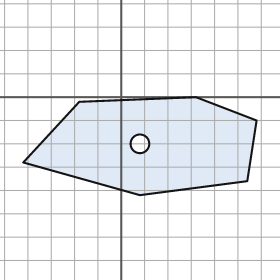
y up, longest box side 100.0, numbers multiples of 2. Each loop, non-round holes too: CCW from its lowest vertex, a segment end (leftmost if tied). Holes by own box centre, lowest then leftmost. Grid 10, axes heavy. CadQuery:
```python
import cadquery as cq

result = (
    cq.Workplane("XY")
    .moveTo(8.0, -42.0)
    .lineTo(54.0, -36.0)
    .lineTo(58.0, -10.0)
    .lineTo(32.0, 0.0)
    .lineTo(-18.0, -2.0)
    .lineTo(-42.0, -28.0)
    .close()
    .moveTo(8.0, -20.0)
    .circle(4.0)
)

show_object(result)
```